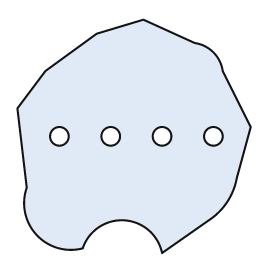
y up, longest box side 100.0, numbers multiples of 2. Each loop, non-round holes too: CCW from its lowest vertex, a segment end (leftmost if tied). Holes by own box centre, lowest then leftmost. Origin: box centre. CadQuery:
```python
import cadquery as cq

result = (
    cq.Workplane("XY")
    .moveTo(12.0, -50.0)
    .lineTo(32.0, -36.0)
    .threePointArc((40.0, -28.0), (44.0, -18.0))
    .lineTo(50.0, 4.0)
    .lineTo(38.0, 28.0)
    .threePointArc((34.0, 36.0), (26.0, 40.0))
    .lineTo(4.0, 50.0)
    .lineTo(-16.0, 44.0)
    .lineTo(-38.0, 28.0)
    .lineTo(-50.0, 12.0)
    .lineTo(-46.0, -22.0)
    .threePointArc((-42.0, -42.0), (-22.0, -48.0))
    .threePointArc((-4.0, -36.0), (12.0, -50.0))
    .close()
    .moveTo(-32.0, 0.0)
    .circle(4.0)
    .moveTo(-10.0, 0.0)
    .circle(4.0)
    .moveTo(12.0, 0.0)
    .circle(4.0)
    .moveTo(34.0, 0.0)
    .circle(4.0)
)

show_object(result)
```